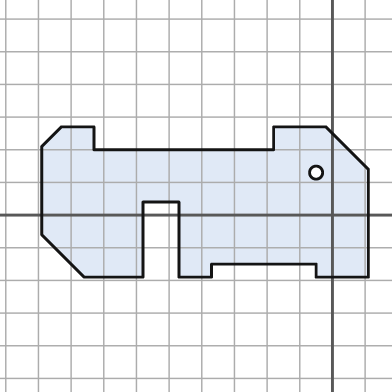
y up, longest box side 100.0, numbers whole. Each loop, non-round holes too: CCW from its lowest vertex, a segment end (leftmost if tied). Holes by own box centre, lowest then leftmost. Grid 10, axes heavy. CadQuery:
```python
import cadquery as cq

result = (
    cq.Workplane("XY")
    .moveTo(-76.0, -19.0)
    .lineTo(-58.0, -19.0)
    .lineTo(-58.0, 4.0)
    .lineTo(-47.0, 4.0)
    .lineTo(-47.0, -19.0)
    .lineTo(-37.0, -19.0)
    .lineTo(-37.0, -15.0)
    .lineTo(-5.0, -15.0)
    .lineTo(-5.0, -19.0)
    .lineTo(11.0, -19.0)
    .lineTo(11.0, 14.0)
    .lineTo(-2.0, 27.0)
    .lineTo(-18.0, 27.0)
    .lineTo(-18.0, 20.0)
    .lineTo(-73.0, 20.0)
    .lineTo(-73.0, 27.0)
    .lineTo(-83.0, 27.0)
    .lineTo(-89.0, 21.0)
    .lineTo(-89.0, -6.0)
    .close()
    .moveTo(-5.0, 13.0)
    .circle(2.0)
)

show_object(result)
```